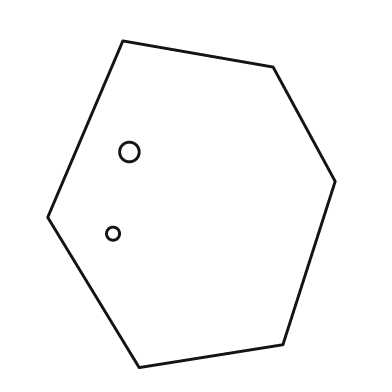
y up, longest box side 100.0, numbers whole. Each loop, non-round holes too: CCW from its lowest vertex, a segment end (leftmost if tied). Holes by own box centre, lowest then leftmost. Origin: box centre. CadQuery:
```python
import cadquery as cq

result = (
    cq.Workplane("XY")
    .moveTo(-16.0, -50.0)
    .lineTo(28.0, -43.0)
    .lineTo(44.0, 7.0)
    .lineTo(25.0, 42.0)
    .lineTo(-21.0, 50.0)
    .lineTo(-44.0, -4.0)
    .close()
    .moveTo(-24.0, -9.0)
    .circle(2.0)
    .moveTo(-19.0, 16.0)
    .circle(3.0)
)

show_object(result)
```